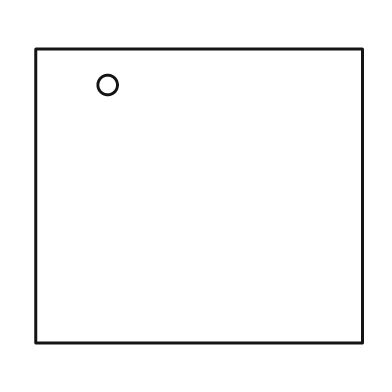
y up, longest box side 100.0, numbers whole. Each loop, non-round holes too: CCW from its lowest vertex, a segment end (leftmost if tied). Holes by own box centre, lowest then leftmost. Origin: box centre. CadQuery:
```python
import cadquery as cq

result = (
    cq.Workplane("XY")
    .moveTo(-50.0, -45.0)
    .lineTo(50.0, -45.0)
    .lineTo(50.0, 45.0)
    .lineTo(-50.0, 45.0)
    .close()
    .moveTo(-28.0, 34.0)
    .circle(3.0)
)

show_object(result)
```